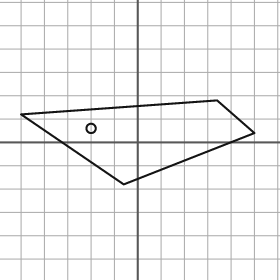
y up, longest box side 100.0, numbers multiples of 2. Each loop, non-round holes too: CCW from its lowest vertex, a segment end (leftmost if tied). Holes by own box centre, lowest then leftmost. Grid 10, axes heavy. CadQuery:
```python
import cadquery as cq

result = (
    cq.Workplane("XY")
    .moveTo(-6.0, -18.0)
    .lineTo(50.0, 4.0)
    .lineTo(34.0, 18.0)
    .lineTo(-50.0, 12.0)
    .close()
    .moveTo(-20.0, 6.0)
    .circle(2.0)
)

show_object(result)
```